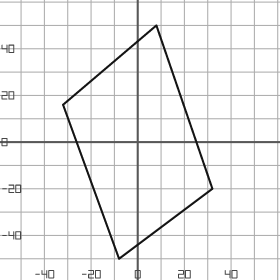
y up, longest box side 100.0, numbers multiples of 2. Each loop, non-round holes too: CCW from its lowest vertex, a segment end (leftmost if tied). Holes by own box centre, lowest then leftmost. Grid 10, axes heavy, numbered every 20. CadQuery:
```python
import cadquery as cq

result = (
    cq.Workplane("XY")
    .moveTo(-8.0, -50.0)
    .lineTo(32.0, -20.0)
    .lineTo(8.0, 50.0)
    .lineTo(-32.0, 16.0)
    .close()
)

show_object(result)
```